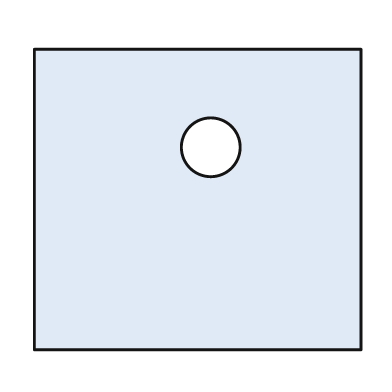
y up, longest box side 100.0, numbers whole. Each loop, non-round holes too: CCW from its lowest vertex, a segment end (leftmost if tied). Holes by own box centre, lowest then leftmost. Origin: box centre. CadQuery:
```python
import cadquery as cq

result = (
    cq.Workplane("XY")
    .moveTo(-50.0, -46.0)
    .lineTo(50.0, -46.0)
    .lineTo(50.0, 46.0)
    .lineTo(-50.0, 46.0)
    .close()
    .moveTo(4.0, 16.0)
    .circle(9.0)
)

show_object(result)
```